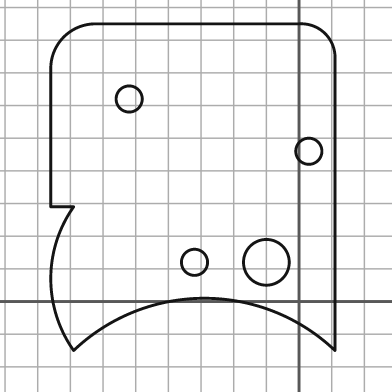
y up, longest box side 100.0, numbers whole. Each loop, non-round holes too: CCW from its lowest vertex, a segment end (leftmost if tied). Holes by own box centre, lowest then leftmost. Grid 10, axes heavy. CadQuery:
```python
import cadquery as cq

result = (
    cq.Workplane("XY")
    .moveTo(-69.0, -15.0)
    .threePointArc((-29.0, 1.0), (11.0, -15.0))
    .lineTo(11.0, 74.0)
    .threePointArc((8.0, 82.0), (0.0, 85.0))
    .lineTo(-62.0, 85.0)
    .threePointArc((-72.0, 81.0), (-76.0, 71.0))
    .lineTo(-76.0, 29.0)
    .lineTo(-69.0, 29.0)
    .threePointArc((-76.0, 7.0), (-69.0, -15.0))
    .close()
    .moveTo(-32.0, 12.0)
    .circle(4.0)
    .moveTo(-10.0, 12.0)
    .circle(7.0)
    .moveTo(3.0, 46.0)
    .circle(4.0)
    .moveTo(-52.0, 62.0)
    .circle(4.0)
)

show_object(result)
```